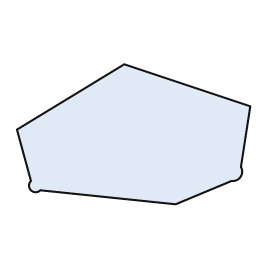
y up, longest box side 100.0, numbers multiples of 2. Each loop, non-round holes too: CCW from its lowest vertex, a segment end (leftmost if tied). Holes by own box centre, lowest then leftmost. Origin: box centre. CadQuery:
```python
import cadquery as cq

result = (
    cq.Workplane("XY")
    .moveTo(18.0, -30.0)
    .lineTo(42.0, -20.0)
    .threePointArc((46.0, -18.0), (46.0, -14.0))
    .lineTo(50.0, 12.0)
    .lineTo(-4.0, 30.0)
    .lineTo(-50.0, 2.0)
    .lineTo(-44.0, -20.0)
    .threePointArc((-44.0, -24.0), (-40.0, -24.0))
    .close()
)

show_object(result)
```